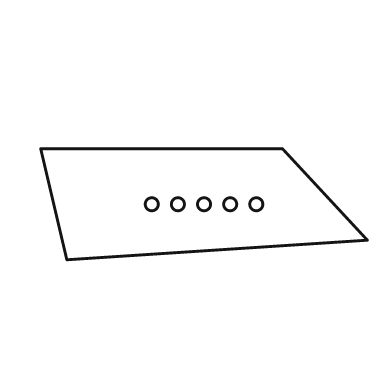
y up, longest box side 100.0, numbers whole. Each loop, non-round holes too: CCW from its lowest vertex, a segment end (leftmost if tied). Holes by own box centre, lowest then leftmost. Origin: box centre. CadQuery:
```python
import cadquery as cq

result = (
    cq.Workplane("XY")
    .moveTo(-42.0, -17.0)
    .lineTo(50.0, -11.0)
    .lineTo(24.0, 17.0)
    .lineTo(-50.0, 17.0)
    .close()
    .moveTo(-16.0, 0.0)
    .circle(2.0)
    .moveTo(-8.0, 0.0)
    .circle(2.0)
    .moveTo(0.0, 0.0)
    .circle(2.0)
    .moveTo(8.0, 0.0)
    .circle(2.0)
    .moveTo(16.0, 0.0)
    .circle(2.0)
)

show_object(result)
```